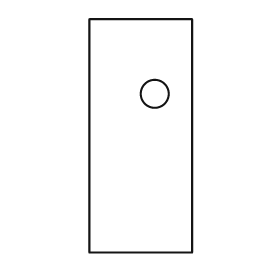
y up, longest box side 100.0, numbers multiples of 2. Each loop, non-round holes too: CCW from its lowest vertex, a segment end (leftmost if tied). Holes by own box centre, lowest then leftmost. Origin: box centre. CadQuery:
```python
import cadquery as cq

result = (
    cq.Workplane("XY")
    .moveTo(-22.0, -50.0)
    .lineTo(22.0, -50.0)
    .lineTo(22.0, 50.0)
    .lineTo(-22.0, 50.0)
    .close()
    .moveTo(6.0, 18.0)
    .circle(6.0)
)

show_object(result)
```